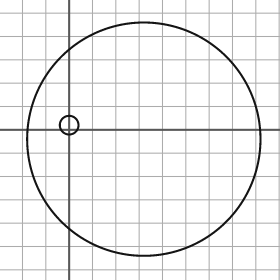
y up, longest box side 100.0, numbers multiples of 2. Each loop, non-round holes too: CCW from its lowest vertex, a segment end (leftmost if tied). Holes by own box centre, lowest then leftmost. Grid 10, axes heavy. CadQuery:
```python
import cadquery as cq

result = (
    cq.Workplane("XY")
    .moveTo(32.0, -4.0)
    .circle(50.0)
    .moveTo(0.0, 2.0)
    .circle(4.0)
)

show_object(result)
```